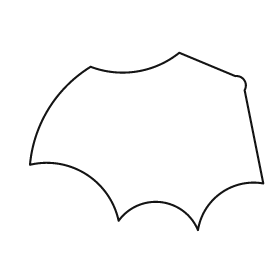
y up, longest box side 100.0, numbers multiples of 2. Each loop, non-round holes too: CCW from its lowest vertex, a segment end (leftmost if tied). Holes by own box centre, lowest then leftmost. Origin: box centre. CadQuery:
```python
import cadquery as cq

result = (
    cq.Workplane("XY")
    .moveTo(22.0, -38.0)
    .threePointArc((32.0, -22.0), (50.0, -18.0))
    .lineTo(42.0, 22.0)
    .threePointArc((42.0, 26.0), (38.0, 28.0))
    .lineTo(14.0, 38.0)
    .threePointArc((-4.0, 30.0), (-24.0, 32.0))
    .threePointArc((-42.0, 14.0), (-50.0, -10.0))
    .threePointArc((-26.0, -14.0), (-12.0, -34.0))
    .threePointArc((6.0, -26.0), (22.0, -38.0))
    .close()
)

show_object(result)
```